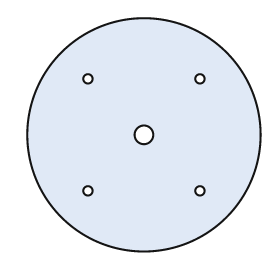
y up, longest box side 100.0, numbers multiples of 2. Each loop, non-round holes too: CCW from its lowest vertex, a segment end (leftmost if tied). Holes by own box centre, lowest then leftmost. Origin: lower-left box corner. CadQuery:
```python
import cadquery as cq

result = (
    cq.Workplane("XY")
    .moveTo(50.0, 50.0)
    .circle(50.0)
    .moveTo(26.0, 26.0)
    .circle(2.0)
    .moveTo(74.0, 26.0)
    .circle(2.0)
    .moveTo(50.0, 50.0)
    .circle(4.0)
    .moveTo(26.0, 74.0)
    .circle(2.0)
    .moveTo(74.0, 74.0)
    .circle(2.0)
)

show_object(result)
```